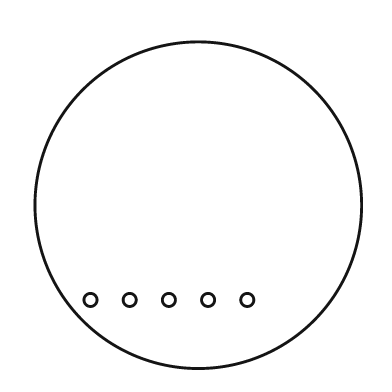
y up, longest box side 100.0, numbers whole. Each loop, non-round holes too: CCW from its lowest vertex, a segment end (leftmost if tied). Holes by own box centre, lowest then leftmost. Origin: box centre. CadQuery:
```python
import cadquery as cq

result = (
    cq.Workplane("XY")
    .moveTo(0.0, 0.0)
    .circle(50.0)
    .moveTo(-33.0, -29.0)
    .circle(2.0)
    .moveTo(-21.0, -29.0)
    .circle(2.0)
    .moveTo(-9.0, -29.0)
    .circle(2.0)
    .moveTo(3.0, -29.0)
    .circle(2.0)
    .moveTo(15.0, -29.0)
    .circle(2.0)
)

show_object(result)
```